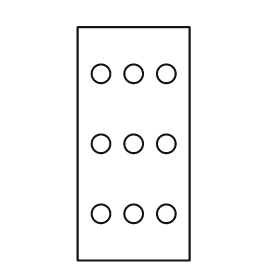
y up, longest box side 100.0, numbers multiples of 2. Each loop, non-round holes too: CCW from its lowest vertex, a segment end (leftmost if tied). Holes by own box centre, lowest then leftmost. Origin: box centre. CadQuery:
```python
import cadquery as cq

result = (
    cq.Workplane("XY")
    .moveTo(-24.0, -50.0)
    .lineTo(24.0, -50.0)
    .lineTo(24.0, 50.0)
    .lineTo(-24.0, 50.0)
    .close()
    .moveTo(-14.0, -30.0)
    .circle(4.0)
    .moveTo(0.0, -30.0)
    .circle(4.0)
    .moveTo(14.0, -30.0)
    .circle(4.0)
    .moveTo(-14.0, 0.0)
    .circle(4.0)
    .moveTo(0.0, 0.0)
    .circle(4.0)
    .moveTo(14.0, 0.0)
    .circle(4.0)
    .moveTo(-14.0, 30.0)
    .circle(4.0)
    .moveTo(0.0, 30.0)
    .circle(4.0)
    .moveTo(14.0, 30.0)
    .circle(4.0)
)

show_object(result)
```